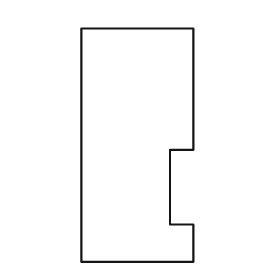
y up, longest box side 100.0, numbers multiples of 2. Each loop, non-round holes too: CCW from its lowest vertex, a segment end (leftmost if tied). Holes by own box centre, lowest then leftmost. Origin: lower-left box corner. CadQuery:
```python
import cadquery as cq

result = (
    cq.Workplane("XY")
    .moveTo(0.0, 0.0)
    .lineTo(48.0, 0.0)
    .lineTo(48.0, 16.0)
    .lineTo(38.0, 16.0)
    .lineTo(38.0, 48.0)
    .lineTo(48.0, 48.0)
    .lineTo(48.0, 100.0)
    .lineTo(0.0, 100.0)
    .close()
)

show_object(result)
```